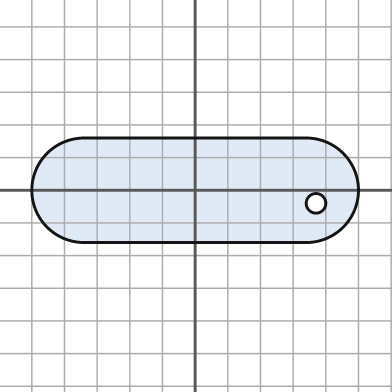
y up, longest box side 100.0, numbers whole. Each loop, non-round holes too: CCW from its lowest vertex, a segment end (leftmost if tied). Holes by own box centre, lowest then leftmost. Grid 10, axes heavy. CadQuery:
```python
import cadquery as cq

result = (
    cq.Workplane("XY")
    .moveTo(-34.0, -16.0)
    .lineTo(34.0, -16.0)
    .threePointArc((50.0, 0.0), (34.0, 16.0))
    .lineTo(-34.0, 16.0)
    .threePointArc((-50.0, 0.0), (-34.0, -16.0))
    .close()
    .moveTo(37.0, -4.0)
    .circle(3.0)
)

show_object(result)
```